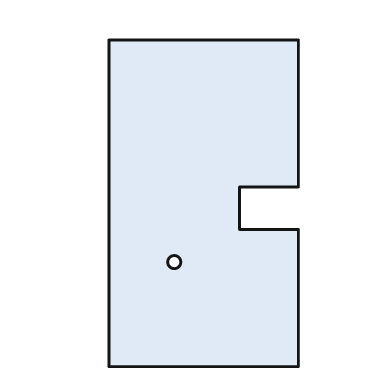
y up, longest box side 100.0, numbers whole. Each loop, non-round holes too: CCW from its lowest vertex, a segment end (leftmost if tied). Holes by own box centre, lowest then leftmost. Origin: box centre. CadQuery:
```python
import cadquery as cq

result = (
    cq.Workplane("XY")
    .moveTo(-29.0, -50.0)
    .lineTo(29.0, -50.0)
    .lineTo(29.0, -8.0)
    .lineTo(11.0, -8.0)
    .lineTo(11.0, 5.0)
    .lineTo(29.0, 5.0)
    .lineTo(29.0, 50.0)
    .lineTo(-29.0, 50.0)
    .close()
    .moveTo(-9.0, -18.0)
    .circle(2.0)
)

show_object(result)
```